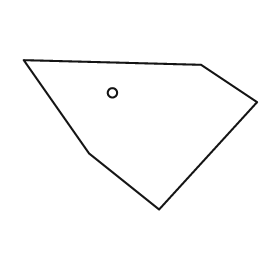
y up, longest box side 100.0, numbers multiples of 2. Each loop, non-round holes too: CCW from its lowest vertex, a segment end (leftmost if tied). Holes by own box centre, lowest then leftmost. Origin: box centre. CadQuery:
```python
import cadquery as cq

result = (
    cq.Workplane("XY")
    .moveTo(8.0, -32.0)
    .lineTo(50.0, 14.0)
    .lineTo(26.0, 30.0)
    .lineTo(-50.0, 32.0)
    .lineTo(-22.0, -8.0)
    .close()
    .moveTo(-12.0, 18.0)
    .circle(2.0)
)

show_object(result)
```